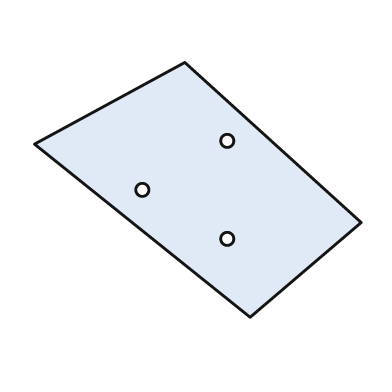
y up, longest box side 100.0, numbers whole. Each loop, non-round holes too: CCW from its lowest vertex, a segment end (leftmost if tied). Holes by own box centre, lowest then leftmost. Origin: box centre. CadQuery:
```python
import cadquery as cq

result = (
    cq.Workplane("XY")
    .moveTo(16.0, -39.0)
    .lineTo(50.0, -10.0)
    .lineTo(-4.0, 39.0)
    .lineTo(-50.0, 14.0)
    .close()
    .moveTo(9.0, -15.0)
    .circle(2.0)
    .moveTo(-17.0, 0.0)
    .circle(2.0)
    .moveTo(9.0, 15.0)
    .circle(2.0)
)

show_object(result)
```